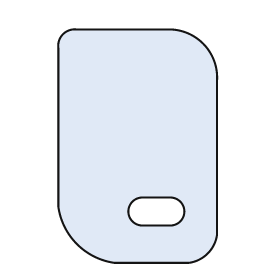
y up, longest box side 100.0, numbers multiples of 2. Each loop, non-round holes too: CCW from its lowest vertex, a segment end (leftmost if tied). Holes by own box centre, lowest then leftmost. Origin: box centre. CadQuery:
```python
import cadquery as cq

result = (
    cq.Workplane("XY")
    .moveTo(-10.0, -50.0)
    .lineTo(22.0, -50.0)
    .threePointArc((30.0, -46.0), (34.0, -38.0))
    .lineTo(34.0, 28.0)
    .threePointArc((28.0, 44.0), (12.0, 50.0))
    .lineTo(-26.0, 50.0)
    .threePointArc((-32.0, 48.0), (-34.0, 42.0))
    .lineTo(-34.0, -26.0)
    .threePointArc((-26.0, -42.0), (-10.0, -50.0))
    .close()
    .moveTo(2.0, -34.0)
    .lineTo(14.0, -34.0)
    .threePointArc((20.0, -28.0), (14.0, -22.0))
    .lineTo(2.0, -22.0)
    .threePointArc((-4.0, -28.0), (2.0, -34.0))
    .close()
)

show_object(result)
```